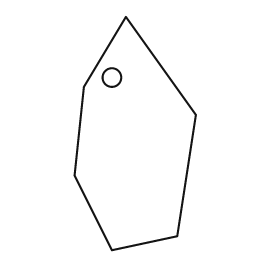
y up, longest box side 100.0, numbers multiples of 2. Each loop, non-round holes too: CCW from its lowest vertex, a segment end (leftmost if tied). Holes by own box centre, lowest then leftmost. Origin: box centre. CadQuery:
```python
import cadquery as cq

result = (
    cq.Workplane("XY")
    .moveTo(-10.0, -50.0)
    .lineTo(18.0, -44.0)
    .lineTo(26.0, 8.0)
    .lineTo(-4.0, 50.0)
    .lineTo(-22.0, 20.0)
    .lineTo(-26.0, -18.0)
    .close()
    .moveTo(-10.0, 24.0)
    .circle(4.0)
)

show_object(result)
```